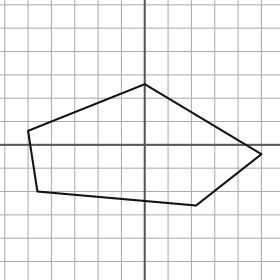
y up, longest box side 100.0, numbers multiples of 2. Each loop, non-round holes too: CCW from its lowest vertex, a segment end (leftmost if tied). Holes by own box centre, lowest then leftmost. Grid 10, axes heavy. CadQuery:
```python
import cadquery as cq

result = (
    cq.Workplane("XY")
    .moveTo(22.0, -26.0)
    .lineTo(50.0, -4.0)
    .lineTo(0.0, 26.0)
    .lineTo(-50.0, 6.0)
    .lineTo(-46.0, -20.0)
    .close()
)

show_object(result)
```